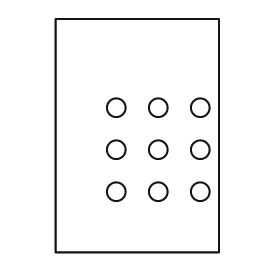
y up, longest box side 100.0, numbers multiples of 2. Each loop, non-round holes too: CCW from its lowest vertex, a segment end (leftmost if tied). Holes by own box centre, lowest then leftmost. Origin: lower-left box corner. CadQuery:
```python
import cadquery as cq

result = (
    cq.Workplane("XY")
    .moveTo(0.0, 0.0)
    .lineTo(70.0, 0.0)
    .lineTo(70.0, 100.0)
    .lineTo(0.0, 100.0)
    .close()
    .moveTo(26.0, 26.0)
    .circle(4.0)
    .moveTo(44.0, 26.0)
    .circle(4.0)
    .moveTo(62.0, 26.0)
    .circle(4.0)
    .moveTo(26.0, 44.0)
    .circle(4.0)
    .moveTo(44.0, 44.0)
    .circle(4.0)
    .moveTo(62.0, 44.0)
    .circle(4.0)
    .moveTo(26.0, 62.0)
    .circle(4.0)
    .moveTo(44.0, 62.0)
    .circle(4.0)
    .moveTo(62.0, 62.0)
    .circle(4.0)
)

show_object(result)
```